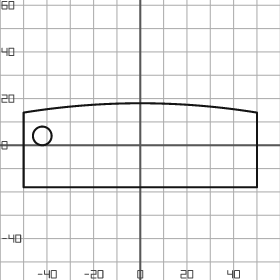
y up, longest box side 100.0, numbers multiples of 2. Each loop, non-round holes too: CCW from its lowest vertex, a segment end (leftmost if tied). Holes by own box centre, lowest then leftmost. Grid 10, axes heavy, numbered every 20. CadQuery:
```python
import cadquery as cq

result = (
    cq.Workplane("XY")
    .moveTo(-50.0, -18.0)
    .lineTo(50.0, -18.0)
    .lineTo(50.0, 14.0)
    .threePointArc((0.0, 18.0), (-50.0, 14.0))
    .close()
    .moveTo(-42.0, 4.0)
    .circle(4.0)
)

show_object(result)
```